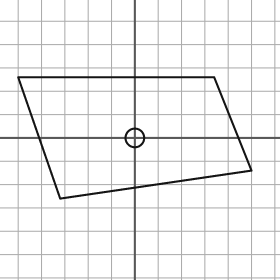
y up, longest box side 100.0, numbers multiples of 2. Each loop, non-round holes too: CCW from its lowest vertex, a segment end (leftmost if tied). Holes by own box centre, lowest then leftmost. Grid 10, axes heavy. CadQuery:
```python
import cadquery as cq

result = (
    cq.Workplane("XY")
    .moveTo(-32.0, -26.0)
    .lineTo(50.0, -14.0)
    .lineTo(34.0, 26.0)
    .lineTo(-50.0, 26.0)
    .close()
    .moveTo(0.0, 0.0)
    .circle(4.0)
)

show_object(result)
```